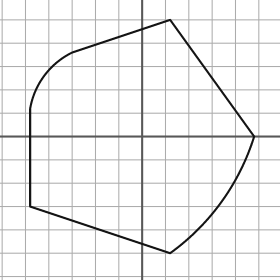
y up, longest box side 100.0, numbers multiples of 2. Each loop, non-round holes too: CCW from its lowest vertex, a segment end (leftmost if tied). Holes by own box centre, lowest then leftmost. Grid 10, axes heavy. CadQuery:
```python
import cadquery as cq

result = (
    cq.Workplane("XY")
    .moveTo(12.0, -50.0)
    .threePointArc((34.0, -28.0), (48.0, 0.0))
    .lineTo(12.0, 50.0)
    .lineTo(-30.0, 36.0)
    .threePointArc((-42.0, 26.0), (-48.0, 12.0))
    .lineTo(-48.0, -30.0)
    .close()
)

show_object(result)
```